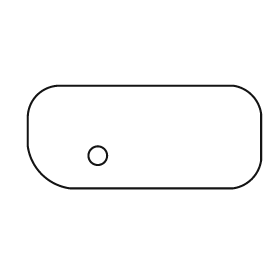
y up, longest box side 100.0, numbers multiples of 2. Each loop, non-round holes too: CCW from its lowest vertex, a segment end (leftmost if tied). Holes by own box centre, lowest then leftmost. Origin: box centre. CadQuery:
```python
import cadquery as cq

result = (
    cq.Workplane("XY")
    .moveTo(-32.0, -22.0)
    .lineTo(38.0, -22.0)
    .threePointArc((46.0, -18.0), (50.0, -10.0))
    .lineTo(50.0, 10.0)
    .threePointArc((46.0, 18.0), (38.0, 22.0))
    .lineTo(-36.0, 22.0)
    .threePointArc((-46.0, 18.0), (-50.0, 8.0))
    .lineTo(-50.0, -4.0)
    .threePointArc((-44.0, -16.0), (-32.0, -22.0))
    .close()
    .moveTo(-20.0, -8.0)
    .circle(4.0)
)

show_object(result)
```